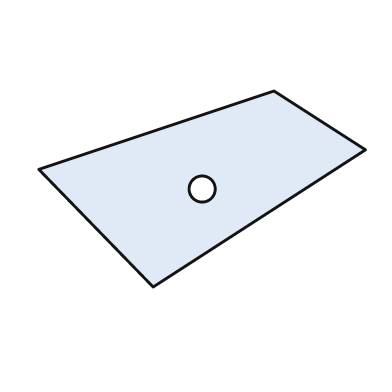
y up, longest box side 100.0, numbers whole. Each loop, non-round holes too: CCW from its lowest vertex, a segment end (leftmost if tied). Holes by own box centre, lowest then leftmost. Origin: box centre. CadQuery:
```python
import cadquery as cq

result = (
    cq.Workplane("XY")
    .moveTo(-15.0, -30.0)
    .lineTo(50.0, 12.0)
    .lineTo(22.0, 30.0)
    .lineTo(-50.0, 6.0)
    .close()
    .moveTo(0.0, 0.0)
    .circle(4.0)
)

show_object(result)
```